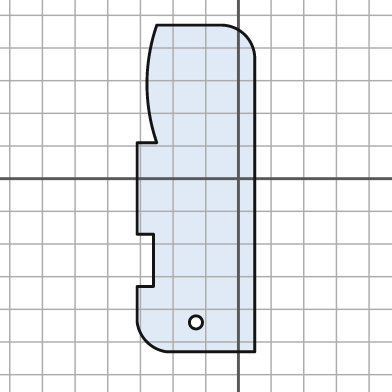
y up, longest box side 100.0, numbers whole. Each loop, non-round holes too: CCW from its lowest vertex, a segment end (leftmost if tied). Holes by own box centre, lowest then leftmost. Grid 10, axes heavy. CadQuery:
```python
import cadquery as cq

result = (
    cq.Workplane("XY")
    .moveTo(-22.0, -53.0)
    .lineTo(5.0, -53.0)
    .lineTo(5.0, 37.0)
    .threePointArc((2.0, 44.0), (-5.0, 47.0))
    .lineTo(-25.0, 47.0)
    .threePointArc((-28.0, 29.0), (-25.0, 11.0))
    .lineTo(-31.0, 11.0)
    .lineTo(-31.0, -17.0)
    .lineTo(-26.0, -17.0)
    .lineTo(-26.0, -33.0)
    .lineTo(-31.0, -33.0)
    .lineTo(-31.0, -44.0)
    .threePointArc((-28.0, -50.0), (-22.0, -53.0))
    .close()
    .moveTo(-13.0, -44.0)
    .circle(2.0)
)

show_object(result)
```